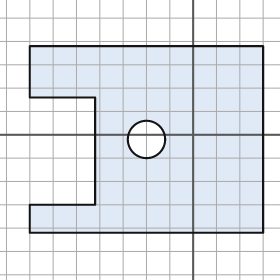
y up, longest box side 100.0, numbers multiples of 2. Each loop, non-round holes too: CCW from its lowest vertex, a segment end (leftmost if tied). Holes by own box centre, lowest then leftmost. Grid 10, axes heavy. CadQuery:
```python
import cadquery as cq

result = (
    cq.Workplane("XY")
    .moveTo(-70.0, -42.0)
    .lineTo(30.0, -42.0)
    .lineTo(30.0, 38.0)
    .lineTo(-70.0, 38.0)
    .lineTo(-70.0, 16.0)
    .lineTo(-42.0, 16.0)
    .lineTo(-42.0, -30.0)
    .lineTo(-70.0, -30.0)
    .close()
    .moveTo(-20.0, -2.0)
    .circle(8.0)
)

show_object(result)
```